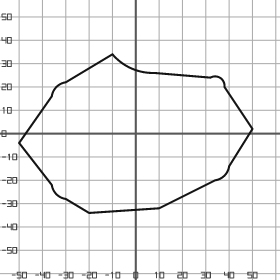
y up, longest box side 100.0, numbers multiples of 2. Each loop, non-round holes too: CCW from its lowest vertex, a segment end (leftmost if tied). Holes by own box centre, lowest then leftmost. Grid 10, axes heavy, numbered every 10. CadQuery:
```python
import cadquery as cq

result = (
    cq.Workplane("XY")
    .moveTo(-20.0, -34.0)
    .lineTo(10.0, -32.0)
    .lineTo(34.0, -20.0)
    .threePointArc((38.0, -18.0), (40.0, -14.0))
    .lineTo(50.0, 2.0)
    .lineTo(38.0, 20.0)
    .threePointArc((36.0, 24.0), (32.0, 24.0))
    .lineTo(8.0, 26.0)
    .threePointArc((-2.0, 28.0), (-10.0, 34.0))
    .lineTo(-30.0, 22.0)
    .threePointArc((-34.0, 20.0), (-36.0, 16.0))
    .lineTo(-50.0, -4.0)
    .lineTo(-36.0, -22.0)
    .threePointArc((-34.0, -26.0), (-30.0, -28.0))
    .close()
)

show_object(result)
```